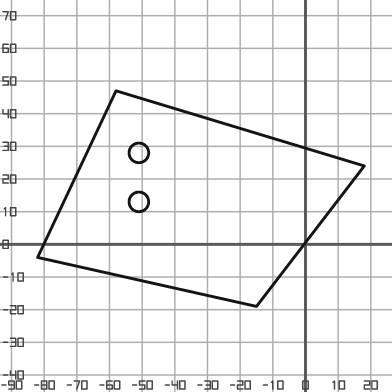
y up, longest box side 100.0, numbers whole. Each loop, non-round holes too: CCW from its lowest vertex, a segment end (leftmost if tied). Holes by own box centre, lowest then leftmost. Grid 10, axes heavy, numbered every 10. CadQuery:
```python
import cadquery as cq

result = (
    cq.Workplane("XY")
    .moveTo(-15.0, -19.0)
    .lineTo(18.0, 24.0)
    .lineTo(-58.0, 47.0)
    .lineTo(-82.0, -4.0)
    .close()
    .moveTo(-51.0, 13.0)
    .circle(3.0)
    .moveTo(-51.0, 28.0)
    .circle(3.0)
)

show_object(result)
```